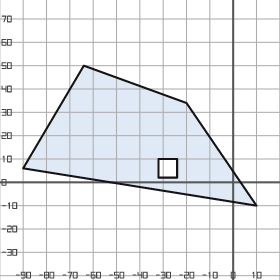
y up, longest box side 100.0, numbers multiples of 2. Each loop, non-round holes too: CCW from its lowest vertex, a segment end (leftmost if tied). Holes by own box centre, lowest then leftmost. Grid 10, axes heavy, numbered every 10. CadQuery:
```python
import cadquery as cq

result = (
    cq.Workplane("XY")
    .moveTo(10.0, -10.0)
    .lineTo(-20.0, 34.0)
    .lineTo(-64.0, 50.0)
    .lineTo(-90.0, 6.0)
    .close()
    .moveTo(-32.0, 2.0)
    .lineTo(-24.0, 2.0)
    .lineTo(-24.0, 10.0)
    .lineTo(-32.0, 10.0)
    .close()
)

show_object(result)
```